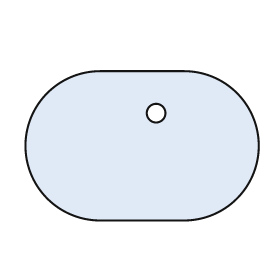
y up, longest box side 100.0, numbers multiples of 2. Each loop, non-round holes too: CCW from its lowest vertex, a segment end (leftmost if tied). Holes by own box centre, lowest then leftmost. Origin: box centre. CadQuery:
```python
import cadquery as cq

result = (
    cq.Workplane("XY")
    .moveTo(-18.0, -32.0)
    .lineTo(18.0, -32.0)
    .threePointArc((50.0, 0.0), (18.0, 32.0))
    .lineTo(-18.0, 32.0)
    .threePointArc((-50.0, 0.0), (-18.0, -32.0))
    .close()
    .moveTo(6.0, 14.0)
    .circle(4.0)
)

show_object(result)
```